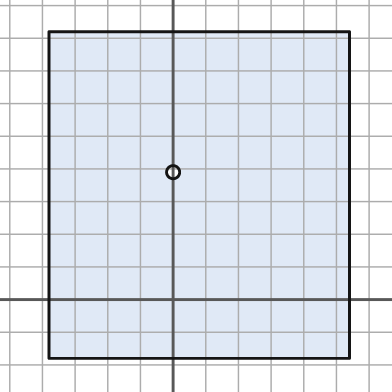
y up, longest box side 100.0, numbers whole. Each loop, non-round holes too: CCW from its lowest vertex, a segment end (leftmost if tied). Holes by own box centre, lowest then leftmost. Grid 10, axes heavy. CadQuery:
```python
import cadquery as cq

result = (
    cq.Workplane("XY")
    .moveTo(-38.0, -18.0)
    .lineTo(54.0, -18.0)
    .lineTo(54.0, 82.0)
    .lineTo(-38.0, 82.0)
    .close()
    .moveTo(0.0, 39.0)
    .circle(2.0)
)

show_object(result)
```